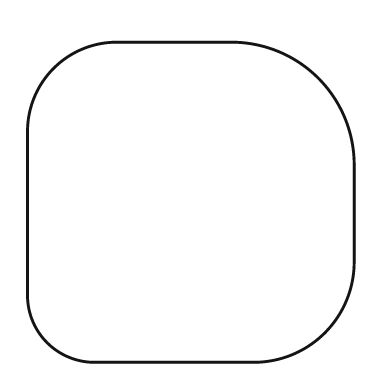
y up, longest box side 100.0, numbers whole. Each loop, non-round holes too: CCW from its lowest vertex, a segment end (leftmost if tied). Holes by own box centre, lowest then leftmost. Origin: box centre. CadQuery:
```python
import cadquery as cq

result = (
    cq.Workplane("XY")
    .moveTo(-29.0, -49.0)
    .lineTo(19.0, -49.0)
    .threePointArc((41.0, -40.0), (50.0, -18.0))
    .lineTo(50.0, 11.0)
    .threePointArc((39.0, 38.0), (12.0, 49.0))
    .lineTo(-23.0, 49.0)
    .threePointArc((-42.0, 41.0), (-50.0, 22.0))
    .lineTo(-50.0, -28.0)
    .threePointArc((-44.0, -43.0), (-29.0, -49.0))
    .close()
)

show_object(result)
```